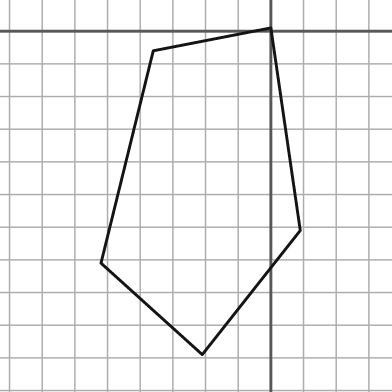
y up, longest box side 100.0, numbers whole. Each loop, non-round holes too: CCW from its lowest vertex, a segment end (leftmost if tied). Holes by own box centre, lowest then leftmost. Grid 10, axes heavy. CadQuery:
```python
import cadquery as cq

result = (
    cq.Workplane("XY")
    .moveTo(-21.0, -99.0)
    .lineTo(9.0, -61.0)
    .lineTo(0.0, 1.0)
    .lineTo(-36.0, -6.0)
    .lineTo(-52.0, -71.0)
    .close()
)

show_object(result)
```